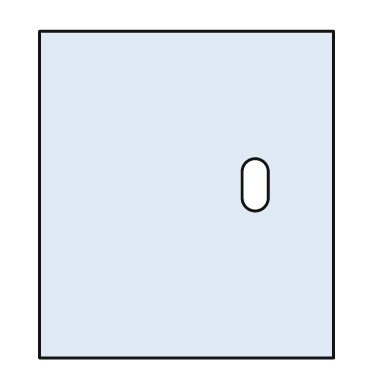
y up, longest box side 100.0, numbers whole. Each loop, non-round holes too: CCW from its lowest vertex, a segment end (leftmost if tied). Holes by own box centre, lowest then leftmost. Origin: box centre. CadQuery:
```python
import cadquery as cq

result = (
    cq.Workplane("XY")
    .moveTo(-45.0, -50.0)
    .lineTo(45.0, -50.0)
    .lineTo(45.0, 50.0)
    .lineTo(-45.0, 50.0)
    .close()
    .moveTo(17.0, -1.0)
    .threePointArc((21.0, -5.0), (25.0, -1.0))
    .lineTo(25.0, 7.0)
    .threePointArc((21.0, 11.0), (17.0, 7.0))
    .close()
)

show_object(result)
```